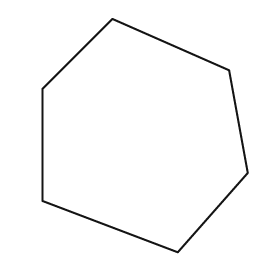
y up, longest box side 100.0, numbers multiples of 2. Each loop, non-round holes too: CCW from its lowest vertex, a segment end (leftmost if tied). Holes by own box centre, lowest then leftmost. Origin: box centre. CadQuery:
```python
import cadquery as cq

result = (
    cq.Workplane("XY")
    .moveTo(14.0, -50.0)
    .lineTo(44.0, -16.0)
    .lineTo(36.0, 28.0)
    .lineTo(-14.0, 50.0)
    .lineTo(-44.0, 20.0)
    .lineTo(-44.0, -28.0)
    .close()
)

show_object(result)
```